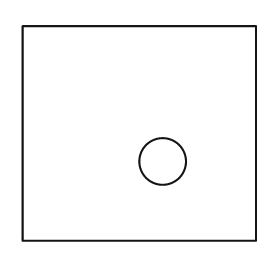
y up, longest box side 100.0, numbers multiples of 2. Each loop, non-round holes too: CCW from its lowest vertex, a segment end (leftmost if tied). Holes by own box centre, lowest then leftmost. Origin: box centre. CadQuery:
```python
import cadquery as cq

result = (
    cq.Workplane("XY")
    .moveTo(-50.0, -46.0)
    .lineTo(50.0, -46.0)
    .lineTo(50.0, 46.0)
    .lineTo(-50.0, 46.0)
    .close()
    .moveTo(10.0, -12.0)
    .circle(10.0)
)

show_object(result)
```